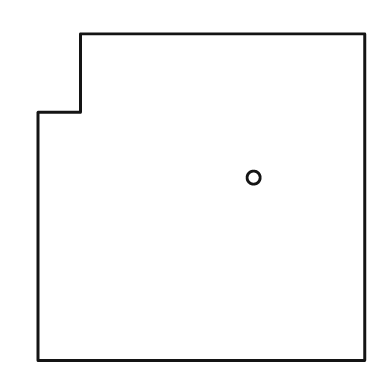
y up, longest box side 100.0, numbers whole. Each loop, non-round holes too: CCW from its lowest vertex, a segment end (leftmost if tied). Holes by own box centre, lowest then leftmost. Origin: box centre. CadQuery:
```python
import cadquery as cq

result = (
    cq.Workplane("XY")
    .moveTo(-50.0, -50.0)
    .lineTo(50.0, -50.0)
    .lineTo(50.0, 50.0)
    .lineTo(-37.0, 50.0)
    .lineTo(-37.0, 26.0)
    .lineTo(-50.0, 26.0)
    .close()
    .moveTo(16.0, 6.0)
    .circle(2.0)
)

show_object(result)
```